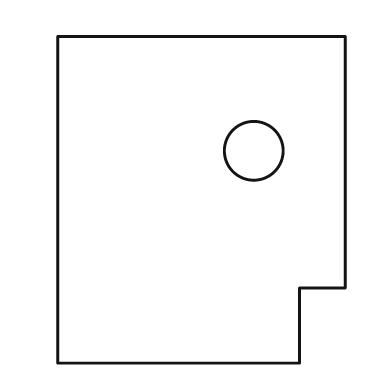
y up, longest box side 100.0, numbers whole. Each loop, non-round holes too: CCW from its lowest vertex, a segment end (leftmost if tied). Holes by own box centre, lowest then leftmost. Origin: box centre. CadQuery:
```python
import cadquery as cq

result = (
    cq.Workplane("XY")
    .moveTo(-44.0, -50.0)
    .lineTo(30.0, -50.0)
    .lineTo(30.0, -27.0)
    .lineTo(44.0, -27.0)
    .lineTo(44.0, 50.0)
    .lineTo(-44.0, 50.0)
    .close()
    .moveTo(16.0, 15.0)
    .circle(9.0)
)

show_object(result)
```